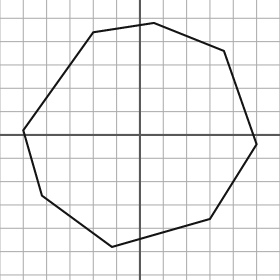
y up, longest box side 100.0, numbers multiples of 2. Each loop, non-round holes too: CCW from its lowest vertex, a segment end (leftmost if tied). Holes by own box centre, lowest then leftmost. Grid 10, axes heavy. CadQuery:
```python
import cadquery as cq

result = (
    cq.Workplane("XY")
    .moveTo(-12.0, -48.0)
    .lineTo(30.0, -36.0)
    .lineTo(50.0, -4.0)
    .lineTo(36.0, 36.0)
    .lineTo(6.0, 48.0)
    .lineTo(-20.0, 44.0)
    .lineTo(-50.0, 2.0)
    .lineTo(-42.0, -26.0)
    .close()
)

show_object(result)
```